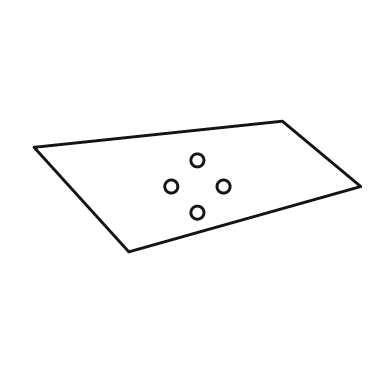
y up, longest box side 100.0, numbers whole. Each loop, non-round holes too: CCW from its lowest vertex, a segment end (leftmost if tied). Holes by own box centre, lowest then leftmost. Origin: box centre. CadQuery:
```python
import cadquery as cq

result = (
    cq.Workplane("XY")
    .moveTo(-21.0, -20.0)
    .lineTo(50.0, 0.0)
    .lineTo(26.0, 20.0)
    .lineTo(-50.0, 12.0)
    .close()
    .moveTo(0.0, -8.0)
    .circle(2.0)
    .moveTo(-8.0, 0.0)
    .circle(2.0)
    .moveTo(8.0, 0.0)
    .circle(2.0)
    .moveTo(0.0, 8.0)
    .circle(2.0)
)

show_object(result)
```